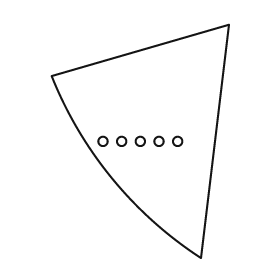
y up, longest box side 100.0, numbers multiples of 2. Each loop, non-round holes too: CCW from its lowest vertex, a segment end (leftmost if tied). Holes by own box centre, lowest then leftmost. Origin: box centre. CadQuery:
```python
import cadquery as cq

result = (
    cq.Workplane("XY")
    .moveTo(26.0, -50.0)
    .lineTo(38.0, 50.0)
    .lineTo(-38.0, 28.0)
    .threePointArc((-12.0, -16.0), (26.0, -50.0))
    .close()
    .moveTo(-16.0, 0.0)
    .circle(2.0)
    .moveTo(-8.0, 0.0)
    .circle(2.0)
    .moveTo(0.0, 0.0)
    .circle(2.0)
    .moveTo(8.0, 0.0)
    .circle(2.0)
    .moveTo(16.0, 0.0)
    .circle(2.0)
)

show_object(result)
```